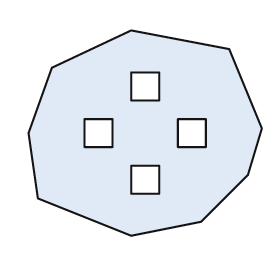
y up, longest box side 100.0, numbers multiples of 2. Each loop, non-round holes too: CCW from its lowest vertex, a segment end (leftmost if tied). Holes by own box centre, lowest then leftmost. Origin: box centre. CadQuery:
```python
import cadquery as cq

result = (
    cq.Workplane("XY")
    .moveTo(-6.0, -44.0)
    .lineTo(24.0, -38.0)
    .lineTo(44.0, -18.0)
    .lineTo(50.0, 2.0)
    .lineTo(36.0, 36.0)
    .lineTo(-6.0, 44.0)
    .lineTo(-40.0, 28.0)
    .lineTo(-50.0, 0.0)
    .lineTo(-46.0, -28.0)
    .close()
    .moveTo(-6.0, -26.0)
    .lineTo(6.0, -26.0)
    .lineTo(6.0, -14.0)
    .lineTo(-6.0, -14.0)
    .close()
    .moveTo(-26.0, -6.0)
    .lineTo(-14.0, -6.0)
    .lineTo(-14.0, 6.0)
    .lineTo(-26.0, 6.0)
    .close()
    .moveTo(14.0, -6.0)
    .lineTo(26.0, -6.0)
    .lineTo(26.0, 6.0)
    .lineTo(14.0, 6.0)
    .close()
    .moveTo(-6.0, 14.0)
    .lineTo(6.0, 14.0)
    .lineTo(6.0, 26.0)
    .lineTo(-6.0, 26.0)
    .close()
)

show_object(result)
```